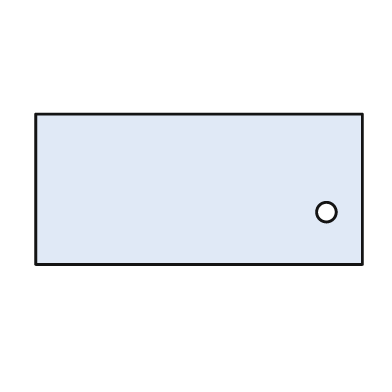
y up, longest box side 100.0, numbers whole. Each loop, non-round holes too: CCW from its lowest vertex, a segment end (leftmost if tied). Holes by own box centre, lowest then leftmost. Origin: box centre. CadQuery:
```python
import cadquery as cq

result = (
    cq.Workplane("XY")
    .moveTo(-50.0, -23.0)
    .lineTo(50.0, -23.0)
    .lineTo(50.0, 23.0)
    .lineTo(-50.0, 23.0)
    .close()
    .moveTo(39.0, -7.0)
    .circle(3.0)
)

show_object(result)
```